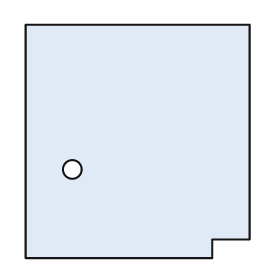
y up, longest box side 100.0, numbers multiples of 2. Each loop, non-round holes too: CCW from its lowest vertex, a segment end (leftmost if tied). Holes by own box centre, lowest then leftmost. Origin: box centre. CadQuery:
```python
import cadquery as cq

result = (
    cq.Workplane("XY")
    .moveTo(-48.0, -50.0)
    .lineTo(32.0, -50.0)
    .lineTo(32.0, -42.0)
    .lineTo(48.0, -42.0)
    .lineTo(48.0, 50.0)
    .lineTo(-48.0, 50.0)
    .close()
    .moveTo(-28.0, -12.0)
    .circle(4.0)
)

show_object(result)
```